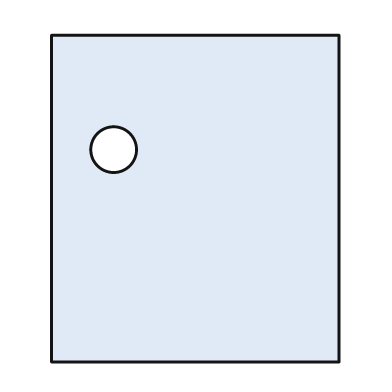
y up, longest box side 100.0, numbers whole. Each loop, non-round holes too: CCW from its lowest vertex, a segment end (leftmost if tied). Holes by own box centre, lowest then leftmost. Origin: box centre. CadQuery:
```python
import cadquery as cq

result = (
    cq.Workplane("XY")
    .moveTo(-44.0, -50.0)
    .lineTo(44.0, -50.0)
    .lineTo(44.0, 50.0)
    .lineTo(-44.0, 50.0)
    .close()
    .moveTo(-25.0, 15.0)
    .circle(7.0)
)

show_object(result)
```